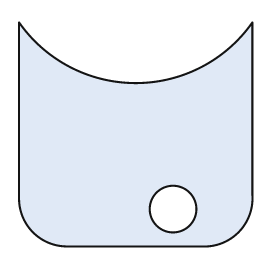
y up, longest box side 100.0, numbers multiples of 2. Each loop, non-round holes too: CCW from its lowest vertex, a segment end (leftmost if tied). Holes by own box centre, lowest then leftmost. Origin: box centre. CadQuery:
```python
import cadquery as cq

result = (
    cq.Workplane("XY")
    .moveTo(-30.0, -48.0)
    .lineTo(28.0, -48.0)
    .threePointArc((44.0, -42.0), (50.0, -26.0))
    .lineTo(50.0, 48.0)
    .threePointArc((0.0, 22.0), (-50.0, 48.0))
    .lineTo(-50.0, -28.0)
    .threePointArc((-44.0, -42.0), (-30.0, -48.0))
    .close()
    .moveTo(16.0, -32.0)
    .circle(10.0)
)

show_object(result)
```